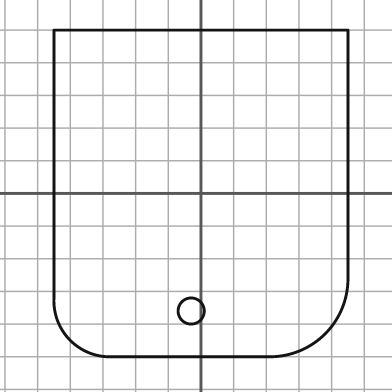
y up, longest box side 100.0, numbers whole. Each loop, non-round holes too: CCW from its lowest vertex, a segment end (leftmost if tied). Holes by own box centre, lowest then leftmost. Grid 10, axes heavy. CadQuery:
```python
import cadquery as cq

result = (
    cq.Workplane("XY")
    .moveTo(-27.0, -50.0)
    .lineTo(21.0, -50.0)
    .threePointArc((38.0, -43.0), (45.0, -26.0))
    .lineTo(45.0, 50.0)
    .lineTo(-45.0, 50.0)
    .lineTo(-45.0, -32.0)
    .threePointArc((-40.0, -45.0), (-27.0, -50.0))
    .close()
    .moveTo(-3.0, -36.0)
    .circle(4.0)
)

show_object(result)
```